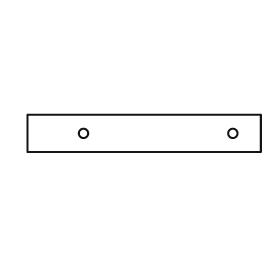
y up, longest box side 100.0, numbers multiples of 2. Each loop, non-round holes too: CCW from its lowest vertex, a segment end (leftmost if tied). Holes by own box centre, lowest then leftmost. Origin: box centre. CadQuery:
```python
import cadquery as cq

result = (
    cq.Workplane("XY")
    .moveTo(-50.0, -8.0)
    .lineTo(50.0, -8.0)
    .lineTo(50.0, 8.0)
    .lineTo(-50.0, 8.0)
    .close()
    .moveTo(-26.0, 0.0)
    .circle(2.0)
    .moveTo(38.0, 0.0)
    .circle(2.0)
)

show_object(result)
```